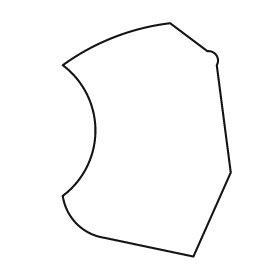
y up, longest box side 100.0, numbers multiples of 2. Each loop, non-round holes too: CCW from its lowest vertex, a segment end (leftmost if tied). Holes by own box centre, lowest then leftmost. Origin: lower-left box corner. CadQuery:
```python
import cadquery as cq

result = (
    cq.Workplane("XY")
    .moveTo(56.0, 0.0)
    .lineTo(72.0, 36.0)
    .lineTo(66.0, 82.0)
    .threePointArc((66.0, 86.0), (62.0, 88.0))
    .lineTo(46.0, 100.0)
    .threePointArc((22.0, 94.0), (0.0, 82.0))
    .threePointArc((14.0, 54.0), (0.0, 26.0))
    .threePointArc((6.0, 14.0), (18.0, 8.0))
    .close()
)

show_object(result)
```